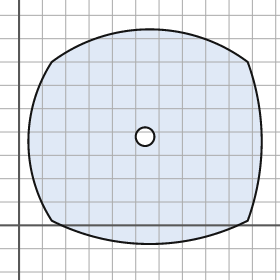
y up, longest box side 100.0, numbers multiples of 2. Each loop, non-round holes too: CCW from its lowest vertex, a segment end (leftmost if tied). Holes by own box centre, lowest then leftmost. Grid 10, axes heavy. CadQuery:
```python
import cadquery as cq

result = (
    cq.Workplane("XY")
    .moveTo(14.0, 2.0)
    .threePointArc((56.0, -8.0), (98.0, 2.0))
    .threePointArc((104.0, 36.0), (98.0, 70.0))
    .threePointArc((56.0, 84.0), (14.0, 70.0))
    .threePointArc((4.0, 36.0), (14.0, 2.0))
    .close()
    .moveTo(54.0, 38.0)
    .circle(4.0)
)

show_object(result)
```